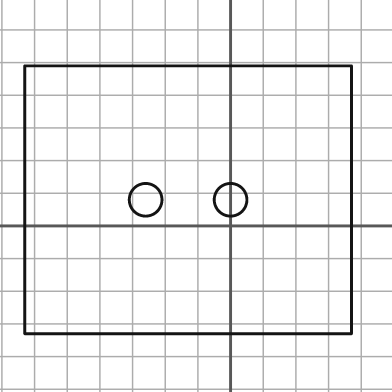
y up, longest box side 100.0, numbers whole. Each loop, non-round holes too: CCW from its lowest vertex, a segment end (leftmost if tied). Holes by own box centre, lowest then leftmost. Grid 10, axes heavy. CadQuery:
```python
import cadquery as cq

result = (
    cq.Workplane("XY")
    .moveTo(-63.0, -33.0)
    .lineTo(37.0, -33.0)
    .lineTo(37.0, 49.0)
    .lineTo(-63.0, 49.0)
    .close()
    .moveTo(-26.0, 8.0)
    .circle(5.0)
    .moveTo(0.0, 8.0)
    .circle(5.0)
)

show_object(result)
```